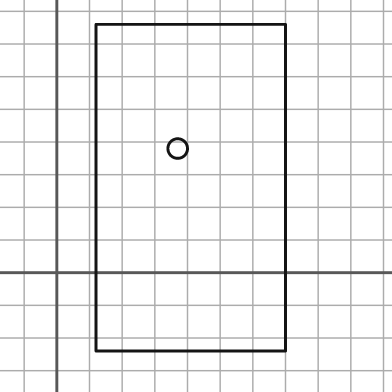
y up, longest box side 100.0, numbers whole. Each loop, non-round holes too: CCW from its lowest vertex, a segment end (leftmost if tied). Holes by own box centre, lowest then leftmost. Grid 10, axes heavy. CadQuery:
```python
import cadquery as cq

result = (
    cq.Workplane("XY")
    .moveTo(12.0, -24.0)
    .lineTo(70.0, -24.0)
    .lineTo(70.0, 76.0)
    .lineTo(12.0, 76.0)
    .close()
    .moveTo(37.0, 38.0)
    .circle(3.0)
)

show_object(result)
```